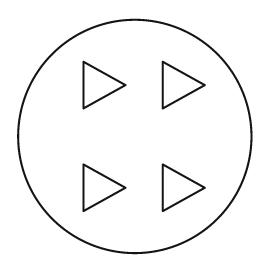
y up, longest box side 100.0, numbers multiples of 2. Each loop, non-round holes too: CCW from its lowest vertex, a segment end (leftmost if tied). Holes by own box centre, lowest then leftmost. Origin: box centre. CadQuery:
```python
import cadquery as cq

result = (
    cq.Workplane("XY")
    .moveTo(0.0, 0.0)
    .circle(50.0)
    .moveTo(-22.0, -32.0)
    .lineTo(-4.0, -22.0)
    .lineTo(-22.0, -12.0)
    .close()
    .moveTo(12.0, -32.0)
    .lineTo(30.0, -22.0)
    .lineTo(12.0, -12.0)
    .close()
    .moveTo(-22.0, 12.0)
    .lineTo(-4.0, 22.0)
    .lineTo(-22.0, 32.0)
    .close()
    .moveTo(12.0, 12.0)
    .lineTo(30.0, 22.0)
    .lineTo(12.0, 32.0)
    .close()
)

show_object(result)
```